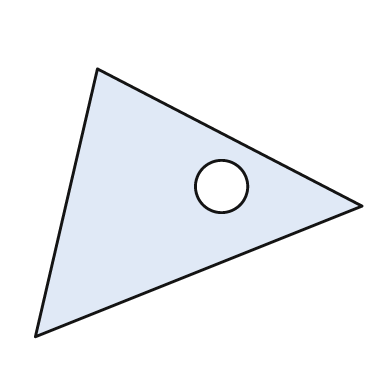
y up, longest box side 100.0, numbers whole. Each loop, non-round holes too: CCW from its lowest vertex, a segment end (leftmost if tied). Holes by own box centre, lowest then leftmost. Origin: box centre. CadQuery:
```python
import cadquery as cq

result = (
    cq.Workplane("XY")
    .moveTo(-50.0, -41.0)
    .lineTo(50.0, -1.0)
    .lineTo(-31.0, 41.0)
    .close()
    .moveTo(7.0, 5.0)
    .circle(8.0)
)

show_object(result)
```